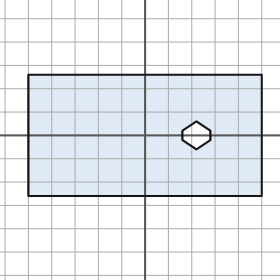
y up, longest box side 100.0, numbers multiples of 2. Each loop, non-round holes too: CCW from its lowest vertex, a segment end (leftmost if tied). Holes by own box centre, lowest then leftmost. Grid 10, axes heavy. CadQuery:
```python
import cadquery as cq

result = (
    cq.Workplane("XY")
    .moveTo(-50.0, -26.0)
    .lineTo(50.0, -26.0)
    .lineTo(50.0, 26.0)
    .lineTo(-50.0, 26.0)
    .close()
    .moveTo(22.0, -6.0)
    .lineTo(28.0, -2.0)
    .lineTo(28.0, 2.0)
    .lineTo(22.0, 6.0)
    .lineTo(16.0, 2.0)
    .lineTo(16.0, -2.0)
    .close()
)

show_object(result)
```